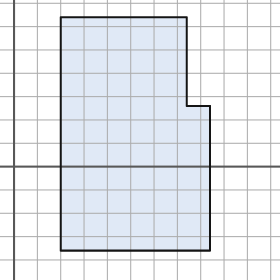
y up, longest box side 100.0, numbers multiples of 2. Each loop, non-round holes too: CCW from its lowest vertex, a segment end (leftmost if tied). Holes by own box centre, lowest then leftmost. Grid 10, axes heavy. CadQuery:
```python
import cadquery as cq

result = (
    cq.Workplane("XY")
    .moveTo(20.0, -36.0)
    .lineTo(84.0, -36.0)
    .lineTo(84.0, 26.0)
    .lineTo(74.0, 26.0)
    .lineTo(74.0, 64.0)
    .lineTo(20.0, 64.0)
    .close()
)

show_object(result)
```